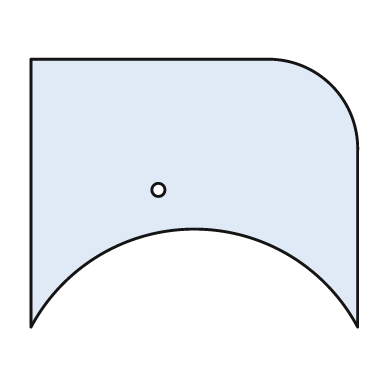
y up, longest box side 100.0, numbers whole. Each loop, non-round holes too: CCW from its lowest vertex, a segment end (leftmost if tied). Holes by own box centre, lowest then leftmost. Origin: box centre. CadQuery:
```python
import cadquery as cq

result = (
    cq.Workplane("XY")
    .moveTo(-50.0, -41.0)
    .threePointArc((0.0, -11.0), (50.0, -41.0))
    .lineTo(50.0, 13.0)
    .threePointArc((42.0, 33.0), (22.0, 41.0))
    .lineTo(-50.0, 41.0)
    .close()
    .moveTo(-11.0, 1.0)
    .circle(2.0)
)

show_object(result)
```